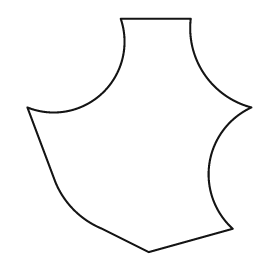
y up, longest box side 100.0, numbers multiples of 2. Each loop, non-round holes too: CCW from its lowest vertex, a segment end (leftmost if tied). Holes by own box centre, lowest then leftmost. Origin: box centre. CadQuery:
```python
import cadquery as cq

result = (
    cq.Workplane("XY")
    .moveTo(4.0, -50.0)
    .lineTo(40.0, -40.0)
    .threePointArc((30.0, -12.0), (48.0, 12.0))
    .threePointArc((28.0, 26.0), (22.0, 50.0))
    .lineTo(-8.0, 50.0)
    .threePointArc((-16.0, 18.0), (-48.0, 12.0))
    .lineTo(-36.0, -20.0)
    .threePointArc((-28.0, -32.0), (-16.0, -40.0))
    .close()
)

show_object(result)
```